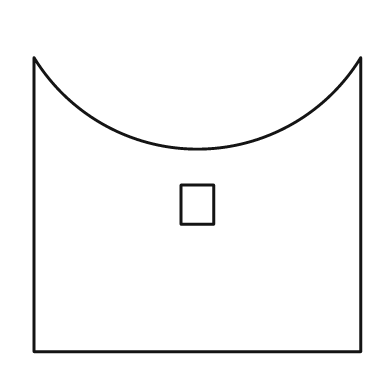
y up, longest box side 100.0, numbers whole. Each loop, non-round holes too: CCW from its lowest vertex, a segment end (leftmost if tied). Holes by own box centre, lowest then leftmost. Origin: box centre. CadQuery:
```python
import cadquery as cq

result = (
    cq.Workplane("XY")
    .moveTo(-50.0, -45.0)
    .lineTo(50.0, -45.0)
    .lineTo(50.0, 45.0)
    .threePointArc((0.0, 17.0), (-50.0, 45.0))
    .close()
    .moveTo(-5.0, -6.0)
    .lineTo(5.0, -6.0)
    .lineTo(5.0, 6.0)
    .lineTo(-5.0, 6.0)
    .close()
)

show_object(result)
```